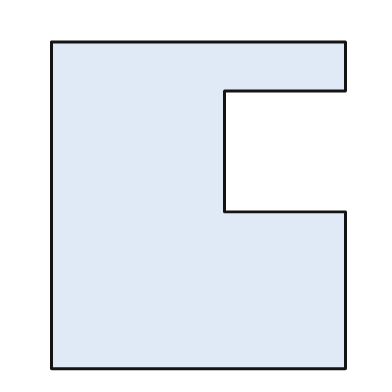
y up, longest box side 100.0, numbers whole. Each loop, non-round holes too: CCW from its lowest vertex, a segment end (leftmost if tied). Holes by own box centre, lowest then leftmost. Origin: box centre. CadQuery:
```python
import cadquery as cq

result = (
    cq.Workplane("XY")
    .moveTo(-45.0, -50.0)
    .lineTo(45.0, -50.0)
    .lineTo(45.0, -2.0)
    .lineTo(8.0, -2.0)
    .lineTo(8.0, 35.0)
    .lineTo(45.0, 35.0)
    .lineTo(45.0, 50.0)
    .lineTo(-45.0, 50.0)
    .close()
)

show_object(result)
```